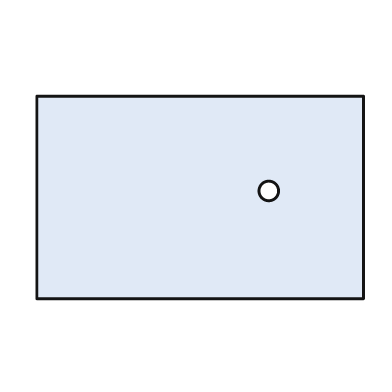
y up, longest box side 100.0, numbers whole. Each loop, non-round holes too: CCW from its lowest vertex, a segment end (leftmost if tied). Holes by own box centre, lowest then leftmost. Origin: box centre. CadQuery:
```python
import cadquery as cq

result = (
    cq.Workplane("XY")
    .moveTo(-50.0, -31.0)
    .lineTo(50.0, -31.0)
    .lineTo(50.0, 31.0)
    .lineTo(-50.0, 31.0)
    .close()
    .moveTo(21.0, 2.0)
    .circle(3.0)
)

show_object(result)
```